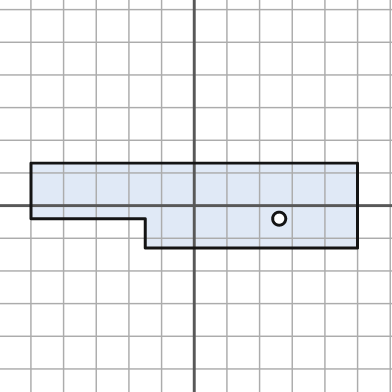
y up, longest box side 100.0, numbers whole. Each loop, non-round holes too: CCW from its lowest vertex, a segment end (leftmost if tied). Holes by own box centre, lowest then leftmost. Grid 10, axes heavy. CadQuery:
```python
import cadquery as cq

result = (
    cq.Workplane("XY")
    .moveTo(-15.0, -13.0)
    .lineTo(50.0, -13.0)
    .lineTo(50.0, 13.0)
    .lineTo(-50.0, 13.0)
    .lineTo(-50.0, -4.0)
    .lineTo(-15.0, -4.0)
    .close()
    .moveTo(26.0, -4.0)
    .circle(2.0)
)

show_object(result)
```